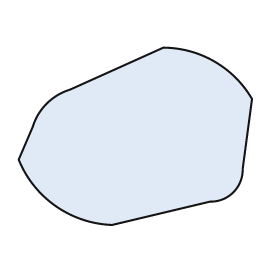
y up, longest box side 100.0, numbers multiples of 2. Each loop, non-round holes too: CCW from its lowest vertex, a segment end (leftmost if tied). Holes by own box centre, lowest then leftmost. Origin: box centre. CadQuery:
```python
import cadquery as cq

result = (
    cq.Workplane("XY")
    .moveTo(-10.0, -38.0)
    .lineTo(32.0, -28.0)
    .threePointArc((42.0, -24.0), (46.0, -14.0))
    .lineTo(50.0, 16.0)
    .threePointArc((34.0, 32.0), (12.0, 38.0))
    .lineTo(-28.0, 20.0)
    .threePointArc((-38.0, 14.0), (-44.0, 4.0))
    .lineTo(-50.0, -10.0)
    .threePointArc((-34.0, -30.0), (-10.0, -38.0))
    .close()
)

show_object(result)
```